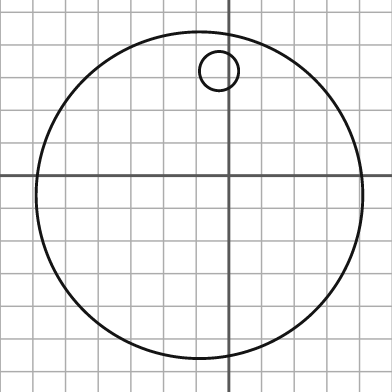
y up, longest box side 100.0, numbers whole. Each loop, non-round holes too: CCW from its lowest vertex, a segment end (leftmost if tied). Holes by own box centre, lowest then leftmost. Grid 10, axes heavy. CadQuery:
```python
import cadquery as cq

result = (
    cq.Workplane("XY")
    .moveTo(-9.0, -6.0)
    .circle(50.0)
    .moveTo(-3.0, 32.0)
    .circle(6.0)
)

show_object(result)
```